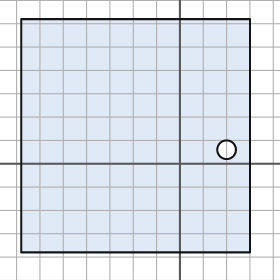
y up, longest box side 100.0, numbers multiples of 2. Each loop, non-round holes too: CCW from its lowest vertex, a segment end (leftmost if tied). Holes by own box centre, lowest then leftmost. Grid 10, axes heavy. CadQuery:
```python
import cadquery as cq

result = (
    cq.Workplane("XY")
    .moveTo(-68.0, -38.0)
    .lineTo(30.0, -38.0)
    .lineTo(30.0, 62.0)
    .lineTo(-68.0, 62.0)
    .close()
    .moveTo(20.0, 6.0)
    .circle(4.0)
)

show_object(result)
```